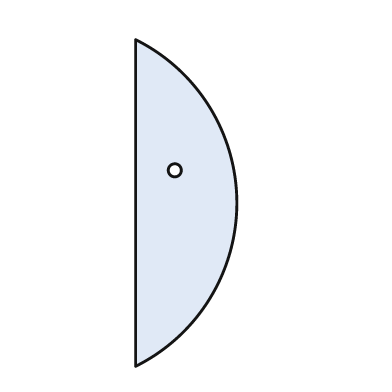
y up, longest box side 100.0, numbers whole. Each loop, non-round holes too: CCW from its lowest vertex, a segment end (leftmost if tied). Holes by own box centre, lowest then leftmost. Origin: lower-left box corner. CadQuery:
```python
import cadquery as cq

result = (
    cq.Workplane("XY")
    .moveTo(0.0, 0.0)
    .threePointArc((31.0, 50.0), (0.0, 100.0))
    .close()
    .moveTo(12.0, 60.0)
    .circle(2.0)
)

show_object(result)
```